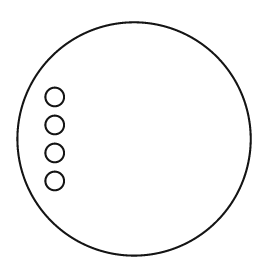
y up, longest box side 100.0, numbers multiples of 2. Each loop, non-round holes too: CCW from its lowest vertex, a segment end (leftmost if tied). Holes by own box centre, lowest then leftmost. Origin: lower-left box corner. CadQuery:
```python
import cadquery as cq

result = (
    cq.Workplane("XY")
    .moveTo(50.0, 50.0)
    .circle(50.0)
    .moveTo(16.0, 32.0)
    .circle(4.0)
    .moveTo(16.0, 44.0)
    .circle(4.0)
    .moveTo(16.0, 56.0)
    .circle(4.0)
    .moveTo(16.0, 68.0)
    .circle(4.0)
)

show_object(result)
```